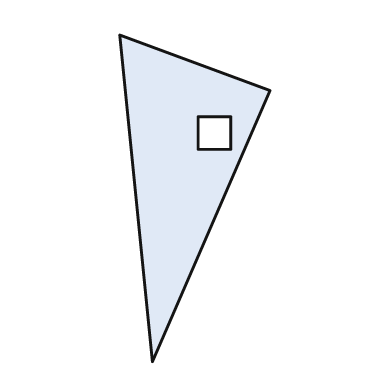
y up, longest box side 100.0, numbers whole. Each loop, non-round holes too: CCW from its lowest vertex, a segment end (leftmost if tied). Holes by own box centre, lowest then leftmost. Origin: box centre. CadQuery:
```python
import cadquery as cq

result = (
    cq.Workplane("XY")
    .moveTo(-13.0, -50.0)
    .lineTo(23.0, 33.0)
    .lineTo(-23.0, 50.0)
    .close()
    .moveTo(1.0, 15.0)
    .lineTo(11.0, 15.0)
    .lineTo(11.0, 25.0)
    .lineTo(1.0, 25.0)
    .close()
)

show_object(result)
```